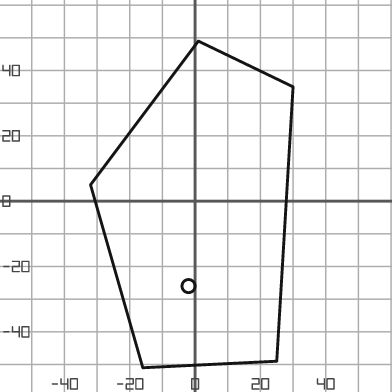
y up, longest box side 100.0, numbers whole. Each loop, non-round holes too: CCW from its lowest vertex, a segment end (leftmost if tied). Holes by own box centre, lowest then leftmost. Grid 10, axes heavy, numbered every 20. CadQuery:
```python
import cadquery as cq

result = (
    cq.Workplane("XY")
    .moveTo(-16.0, -51.0)
    .lineTo(25.0, -49.0)
    .lineTo(30.0, 35.0)
    .lineTo(1.0, 49.0)
    .lineTo(-32.0, 5.0)
    .close()
    .moveTo(-2.0, -26.0)
    .circle(2.0)
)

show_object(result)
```